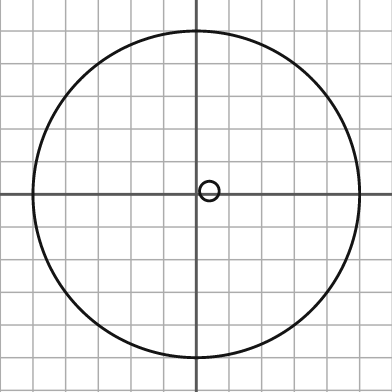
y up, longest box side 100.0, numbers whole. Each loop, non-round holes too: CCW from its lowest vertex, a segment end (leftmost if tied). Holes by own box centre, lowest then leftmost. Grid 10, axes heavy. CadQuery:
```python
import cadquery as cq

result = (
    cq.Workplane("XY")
    .moveTo(0.0, 0.0)
    .circle(50.0)
    .moveTo(4.0, 1.0)
    .circle(3.0)
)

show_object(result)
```